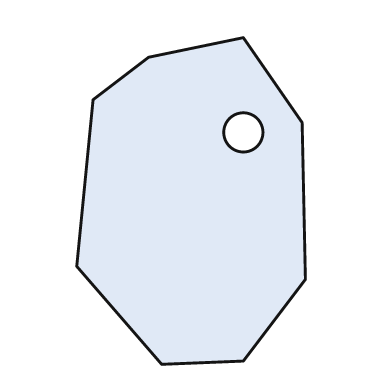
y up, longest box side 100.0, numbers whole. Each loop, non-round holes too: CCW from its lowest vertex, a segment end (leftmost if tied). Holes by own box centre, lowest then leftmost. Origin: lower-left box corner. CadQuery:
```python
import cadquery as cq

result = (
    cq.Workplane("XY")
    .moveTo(26.0, 0.0)
    .lineTo(51.0, 1.0)
    .lineTo(70.0, 26.0)
    .lineTo(69.0, 74.0)
    .lineTo(51.0, 100.0)
    .lineTo(22.0, 94.0)
    .lineTo(5.0, 81.0)
    .lineTo(0.0, 30.0)
    .close()
    .moveTo(51.0, 71.0)
    .circle(6.0)
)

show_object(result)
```